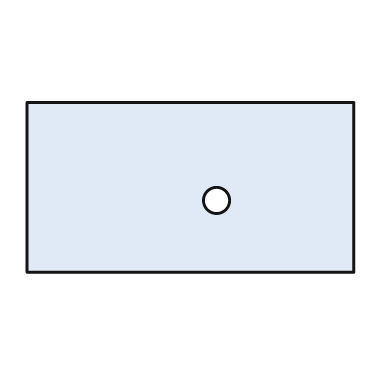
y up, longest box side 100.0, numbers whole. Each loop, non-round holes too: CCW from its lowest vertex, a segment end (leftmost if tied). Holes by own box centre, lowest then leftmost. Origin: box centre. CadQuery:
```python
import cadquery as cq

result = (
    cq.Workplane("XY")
    .moveTo(-50.0, -26.0)
    .lineTo(50.0, -26.0)
    .lineTo(50.0, 26.0)
    .lineTo(-50.0, 26.0)
    .close()
    .moveTo(8.0, -4.0)
    .circle(4.0)
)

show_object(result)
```